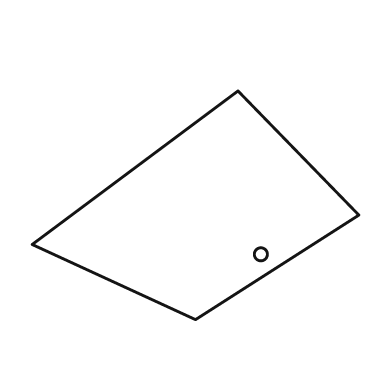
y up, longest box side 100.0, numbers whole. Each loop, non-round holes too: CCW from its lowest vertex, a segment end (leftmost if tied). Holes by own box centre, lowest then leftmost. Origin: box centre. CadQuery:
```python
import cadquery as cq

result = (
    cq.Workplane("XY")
    .moveTo(0.0, -35.0)
    .lineTo(50.0, -3.0)
    .lineTo(13.0, 35.0)
    .lineTo(-50.0, -12.0)
    .close()
    .moveTo(20.0, -15.0)
    .circle(2.0)
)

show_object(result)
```